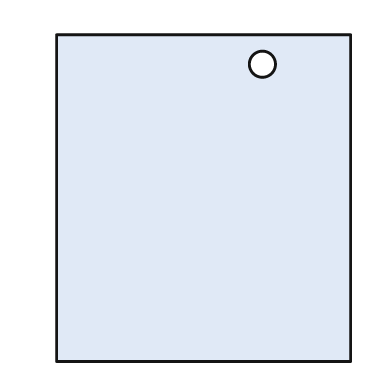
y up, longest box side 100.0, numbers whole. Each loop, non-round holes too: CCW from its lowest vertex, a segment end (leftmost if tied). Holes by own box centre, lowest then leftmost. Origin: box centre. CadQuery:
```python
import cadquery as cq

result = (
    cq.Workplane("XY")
    .moveTo(-45.0, -50.0)
    .lineTo(45.0, -50.0)
    .lineTo(45.0, 50.0)
    .lineTo(-45.0, 50.0)
    .close()
    .moveTo(18.0, 41.0)
    .circle(4.0)
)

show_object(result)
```